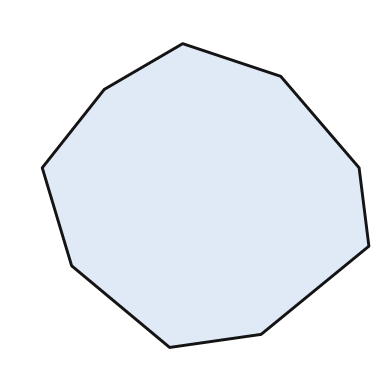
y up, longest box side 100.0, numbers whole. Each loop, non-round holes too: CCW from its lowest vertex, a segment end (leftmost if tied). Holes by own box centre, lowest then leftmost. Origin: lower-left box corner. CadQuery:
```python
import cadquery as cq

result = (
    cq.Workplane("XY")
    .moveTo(39.0, 0.0)
    .lineTo(67.0, 4.0)
    .lineTo(100.0, 31.0)
    .lineTo(97.0, 55.0)
    .lineTo(73.0, 83.0)
    .lineTo(43.0, 93.0)
    .lineTo(19.0, 79.0)
    .lineTo(0.0, 55.0)
    .lineTo(9.0, 25.0)
    .close()
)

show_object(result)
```